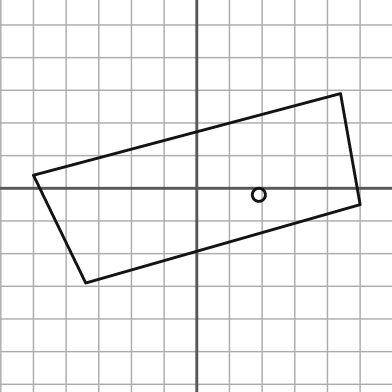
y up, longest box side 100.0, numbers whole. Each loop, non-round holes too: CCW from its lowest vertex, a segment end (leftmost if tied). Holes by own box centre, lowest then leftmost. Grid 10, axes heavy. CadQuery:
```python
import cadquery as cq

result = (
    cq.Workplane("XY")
    .moveTo(-34.0, -29.0)
    .lineTo(50.0, -5.0)
    .lineTo(44.0, 29.0)
    .lineTo(-50.0, 4.0)
    .close()
    .moveTo(19.0, -2.0)
    .circle(2.0)
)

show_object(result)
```